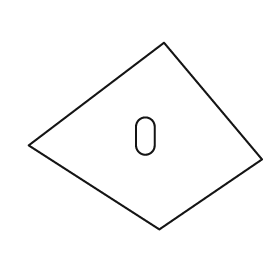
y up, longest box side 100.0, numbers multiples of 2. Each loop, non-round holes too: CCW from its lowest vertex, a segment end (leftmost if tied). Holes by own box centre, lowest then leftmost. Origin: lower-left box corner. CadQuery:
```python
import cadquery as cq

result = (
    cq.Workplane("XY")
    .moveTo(56.0, 0.0)
    .lineTo(100.0, 30.0)
    .lineTo(58.0, 80.0)
    .lineTo(0.0, 36.0)
    .close()
    .moveTo(46.0, 36.0)
    .threePointArc((50.0, 32.0), (54.0, 36.0))
    .lineTo(54.0, 44.0)
    .threePointArc((50.0, 48.0), (46.0, 44.0))
    .close()
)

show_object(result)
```